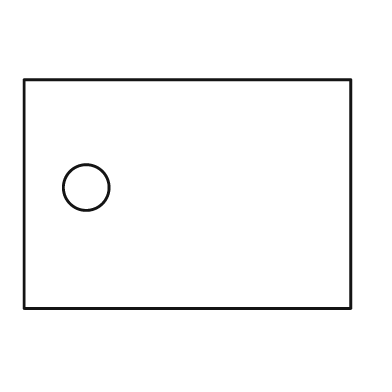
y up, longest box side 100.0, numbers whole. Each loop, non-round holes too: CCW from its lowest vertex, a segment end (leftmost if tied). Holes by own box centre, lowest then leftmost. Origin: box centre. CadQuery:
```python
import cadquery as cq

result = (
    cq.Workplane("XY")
    .moveTo(-50.0, -35.0)
    .lineTo(50.0, -35.0)
    .lineTo(50.0, 35.0)
    .lineTo(-50.0, 35.0)
    .close()
    .moveTo(-31.0, 2.0)
    .circle(7.0)
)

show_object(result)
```